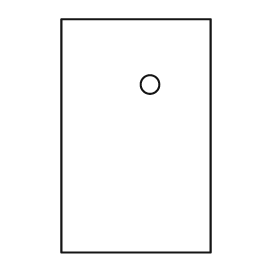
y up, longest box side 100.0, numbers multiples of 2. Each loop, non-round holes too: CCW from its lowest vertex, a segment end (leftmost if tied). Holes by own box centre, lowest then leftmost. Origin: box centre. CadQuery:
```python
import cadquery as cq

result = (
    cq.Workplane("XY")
    .moveTo(-32.0, -50.0)
    .lineTo(32.0, -50.0)
    .lineTo(32.0, 50.0)
    .lineTo(-32.0, 50.0)
    .close()
    .moveTo(6.0, 22.0)
    .circle(4.0)
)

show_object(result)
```